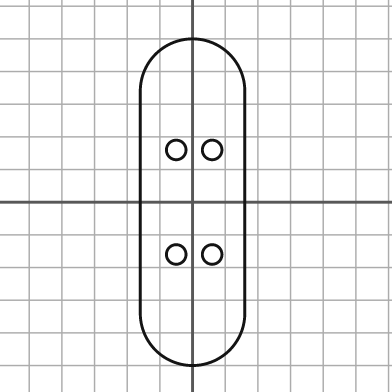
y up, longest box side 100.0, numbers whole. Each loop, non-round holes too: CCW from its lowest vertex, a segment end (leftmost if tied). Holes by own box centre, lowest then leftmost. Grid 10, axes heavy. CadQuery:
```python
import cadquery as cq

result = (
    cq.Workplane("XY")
    .moveTo(-16.0, -34.0)
    .threePointArc((0.0, -50.0), (16.0, -34.0))
    .lineTo(16.0, 34.0)
    .threePointArc((0.0, 50.0), (-16.0, 34.0))
    .close()
    .moveTo(-5.0, -16.0)
    .circle(3.0)
    .moveTo(6.0, -16.0)
    .circle(3.0)
    .moveTo(-5.0, 16.0)
    .circle(3.0)
    .moveTo(6.0, 16.0)
    .circle(3.0)
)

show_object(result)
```